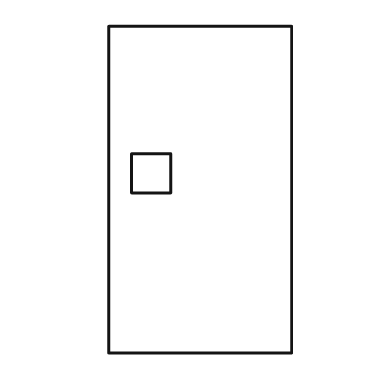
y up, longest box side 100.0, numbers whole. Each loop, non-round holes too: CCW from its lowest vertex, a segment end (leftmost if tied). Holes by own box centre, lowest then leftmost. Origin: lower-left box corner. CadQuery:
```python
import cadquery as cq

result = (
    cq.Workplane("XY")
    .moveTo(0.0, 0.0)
    .lineTo(56.0, 0.0)
    .lineTo(56.0, 100.0)
    .lineTo(0.0, 100.0)
    .close()
    .moveTo(7.0, 49.0)
    .lineTo(19.0, 49.0)
    .lineTo(19.0, 61.0)
    .lineTo(7.0, 61.0)
    .close()
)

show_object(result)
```